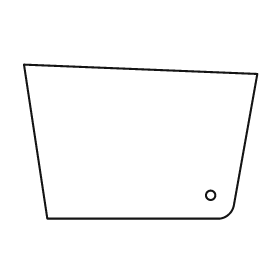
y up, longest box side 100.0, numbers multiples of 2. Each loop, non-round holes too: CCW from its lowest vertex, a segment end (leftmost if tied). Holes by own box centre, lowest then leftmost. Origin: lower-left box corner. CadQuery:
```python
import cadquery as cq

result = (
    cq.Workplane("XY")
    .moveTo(10.0, 0.0)
    .lineTo(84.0, 0.0)
    .threePointArc((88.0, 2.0), (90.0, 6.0))
    .lineTo(100.0, 62.0)
    .lineTo(0.0, 66.0)
    .close()
    .moveTo(80.0, 10.0)
    .circle(2.0)
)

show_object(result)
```